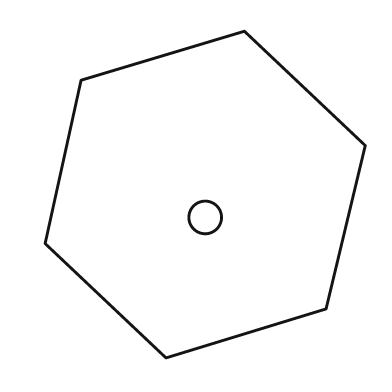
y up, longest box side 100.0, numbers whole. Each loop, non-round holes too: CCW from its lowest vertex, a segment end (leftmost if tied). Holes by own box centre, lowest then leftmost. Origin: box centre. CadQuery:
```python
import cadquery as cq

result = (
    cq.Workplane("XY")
    .moveTo(-12.0, -50.0)
    .lineTo(37.0, -35.0)
    .lineTo(49.0, 15.0)
    .lineTo(12.0, 50.0)
    .lineTo(-38.0, 35.0)
    .lineTo(-49.0, -15.0)
    .close()
    .moveTo(0.0, -7.0)
    .circle(5.0)
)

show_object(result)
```